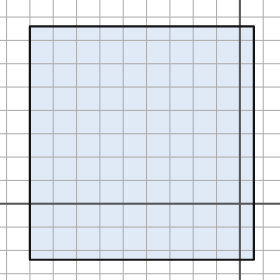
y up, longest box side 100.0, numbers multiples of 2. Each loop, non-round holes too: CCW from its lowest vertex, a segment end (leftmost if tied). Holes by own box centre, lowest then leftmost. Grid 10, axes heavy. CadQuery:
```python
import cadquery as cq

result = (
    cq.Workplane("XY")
    .moveTo(-90.0, -24.0)
    .lineTo(6.0, -24.0)
    .lineTo(6.0, 76.0)
    .lineTo(-90.0, 76.0)
    .close()
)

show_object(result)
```